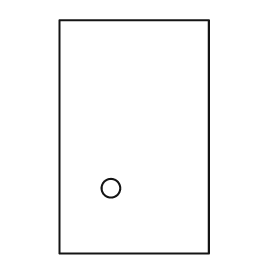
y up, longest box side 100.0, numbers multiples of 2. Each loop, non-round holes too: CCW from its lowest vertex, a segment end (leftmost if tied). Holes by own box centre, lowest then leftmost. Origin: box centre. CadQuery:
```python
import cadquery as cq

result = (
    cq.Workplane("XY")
    .moveTo(-32.0, -50.0)
    .lineTo(32.0, -50.0)
    .lineTo(32.0, 50.0)
    .lineTo(-32.0, 50.0)
    .close()
    .moveTo(-10.0, -22.0)
    .circle(4.0)
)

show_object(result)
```